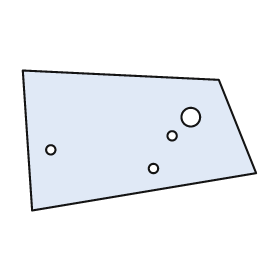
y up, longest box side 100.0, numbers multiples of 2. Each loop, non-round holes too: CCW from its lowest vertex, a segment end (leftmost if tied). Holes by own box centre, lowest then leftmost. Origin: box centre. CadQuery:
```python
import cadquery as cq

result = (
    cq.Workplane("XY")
    .moveTo(-46.0, -30.0)
    .lineTo(50.0, -14.0)
    .lineTo(34.0, 26.0)
    .lineTo(-50.0, 30.0)
    .close()
    .moveTo(6.0, -12.0)
    .circle(2.0)
    .moveTo(-38.0, -4.0)
    .circle(2.0)
    .moveTo(14.0, 2.0)
    .circle(2.0)
    .moveTo(22.0, 10.0)
    .circle(4.0)
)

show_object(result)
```